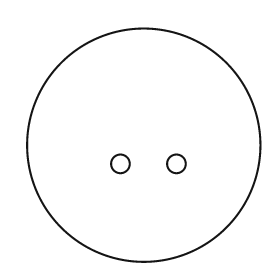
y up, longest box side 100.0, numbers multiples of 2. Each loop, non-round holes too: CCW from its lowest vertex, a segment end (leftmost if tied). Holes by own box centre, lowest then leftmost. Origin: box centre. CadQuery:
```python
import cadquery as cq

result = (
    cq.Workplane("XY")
    .moveTo(0.0, 0.0)
    .circle(50.0)
    .moveTo(-10.0, -8.0)
    .circle(4.0)
    .moveTo(14.0, -8.0)
    .circle(4.0)
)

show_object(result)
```